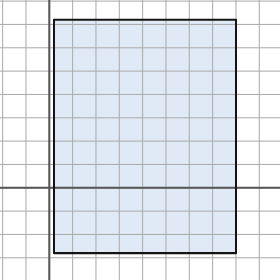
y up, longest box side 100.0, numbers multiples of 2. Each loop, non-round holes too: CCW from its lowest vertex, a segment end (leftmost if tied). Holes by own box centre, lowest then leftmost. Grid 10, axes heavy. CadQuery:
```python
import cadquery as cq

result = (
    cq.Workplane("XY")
    .moveTo(2.0, -28.0)
    .lineTo(80.0, -28.0)
    .lineTo(80.0, 72.0)
    .lineTo(2.0, 72.0)
    .close()
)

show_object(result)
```